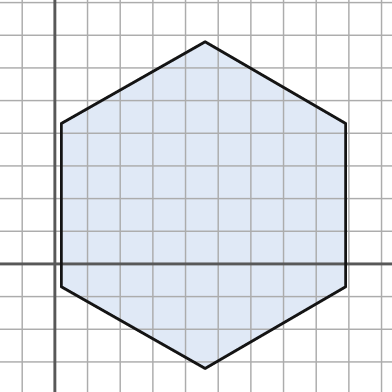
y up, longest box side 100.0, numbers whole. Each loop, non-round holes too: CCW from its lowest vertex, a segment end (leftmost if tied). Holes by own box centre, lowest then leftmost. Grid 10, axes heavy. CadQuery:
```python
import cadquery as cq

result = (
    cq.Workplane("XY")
    .moveTo(46.0, -32.0)
    .lineTo(89.0, -7.0)
    .lineTo(89.0, 43.0)
    .lineTo(46.0, 68.0)
    .lineTo(2.0, 43.0)
    .lineTo(2.0, -7.0)
    .close()
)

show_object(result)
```